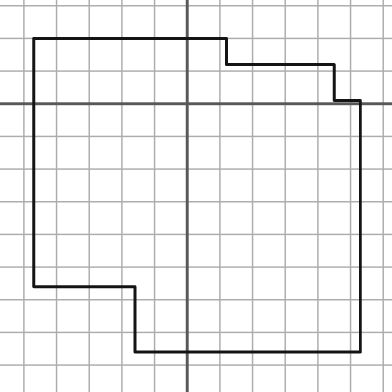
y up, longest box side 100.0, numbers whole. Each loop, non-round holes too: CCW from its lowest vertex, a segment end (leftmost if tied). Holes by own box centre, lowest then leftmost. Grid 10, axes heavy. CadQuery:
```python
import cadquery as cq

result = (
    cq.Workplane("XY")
    .moveTo(-16.0, -76.0)
    .lineTo(53.0, -76.0)
    .lineTo(53.0, 1.0)
    .lineTo(45.0, 1.0)
    .lineTo(45.0, 12.0)
    .lineTo(12.0, 12.0)
    .lineTo(12.0, 20.0)
    .lineTo(-47.0, 20.0)
    .lineTo(-47.0, -56.0)
    .lineTo(-16.0, -56.0)
    .close()
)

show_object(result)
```